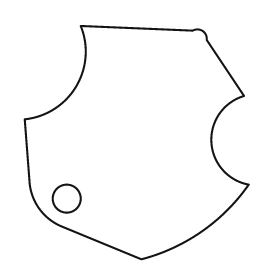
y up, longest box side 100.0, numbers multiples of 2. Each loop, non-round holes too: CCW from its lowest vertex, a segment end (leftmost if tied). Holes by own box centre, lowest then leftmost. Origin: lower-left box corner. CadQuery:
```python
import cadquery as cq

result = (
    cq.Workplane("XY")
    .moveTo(50.0, 0.0)
    .threePointArc((76.0, 12.0), (96.0, 32.0))
    .threePointArc((80.0, 50.0), (94.0, 70.0))
    .lineTo(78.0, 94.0)
    .threePointArc((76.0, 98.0), (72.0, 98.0))
    .lineTo(24.0, 100.0)
    .threePointArc((22.0, 74.0), (0.0, 60.0))
    .lineTo(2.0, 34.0)
    .threePointArc((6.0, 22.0), (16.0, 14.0))
    .close()
    .moveTo(18.0, 26.0)
    .circle(6.0)
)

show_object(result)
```